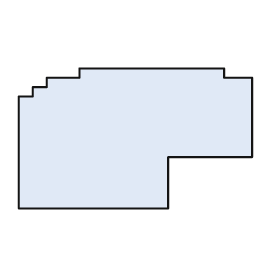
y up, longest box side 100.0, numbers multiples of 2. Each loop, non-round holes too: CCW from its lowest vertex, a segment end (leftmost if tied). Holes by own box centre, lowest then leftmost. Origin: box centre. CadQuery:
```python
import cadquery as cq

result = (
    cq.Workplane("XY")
    .moveTo(-50.0, -30.0)
    .lineTo(14.0, -30.0)
    .lineTo(14.0, -8.0)
    .lineTo(50.0, -8.0)
    .lineTo(50.0, 26.0)
    .lineTo(38.0, 26.0)
    .lineTo(38.0, 30.0)
    .lineTo(-24.0, 30.0)
    .lineTo(-24.0, 26.0)
    .lineTo(-38.0, 26.0)
    .lineTo(-38.0, 22.0)
    .lineTo(-44.0, 22.0)
    .lineTo(-44.0, 18.0)
    .lineTo(-50.0, 18.0)
    .close()
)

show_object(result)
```